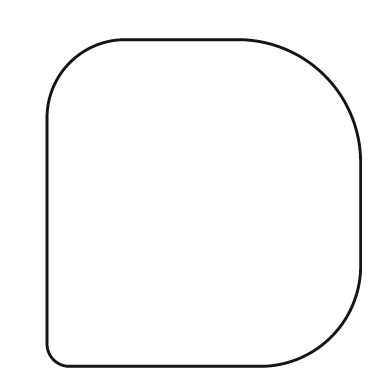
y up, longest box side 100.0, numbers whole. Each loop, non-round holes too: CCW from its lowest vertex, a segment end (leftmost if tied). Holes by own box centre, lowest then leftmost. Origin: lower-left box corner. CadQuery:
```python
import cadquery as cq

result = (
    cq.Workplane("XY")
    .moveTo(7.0, 0.0)
    .lineTo(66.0, 0.0)
    .threePointArc((87.0, 9.0), (96.0, 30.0))
    .lineTo(96.0, 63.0)
    .threePointArc((85.0, 89.0), (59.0, 100.0))
    .lineTo(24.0, 100.0)
    .threePointArc((7.0, 93.0), (0.0, 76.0))
    .lineTo(0.0, 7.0)
    .threePointArc((2.0, 2.0), (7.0, 0.0))
    .close()
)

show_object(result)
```